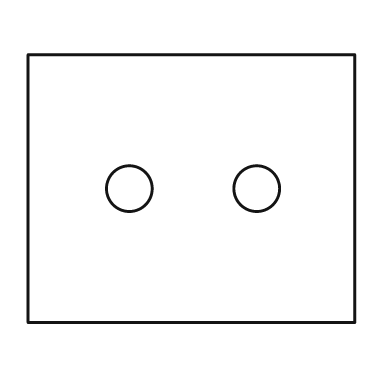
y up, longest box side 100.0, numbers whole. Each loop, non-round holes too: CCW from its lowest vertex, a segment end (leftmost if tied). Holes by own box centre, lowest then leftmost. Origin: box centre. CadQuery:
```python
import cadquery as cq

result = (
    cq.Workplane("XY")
    .moveTo(-50.0, -41.0)
    .lineTo(50.0, -41.0)
    .lineTo(50.0, 41.0)
    .lineTo(-50.0, 41.0)
    .close()
    .moveTo(-19.0, 0.0)
    .circle(7.0)
    .moveTo(20.0, 0.0)
    .circle(7.0)
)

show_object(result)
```